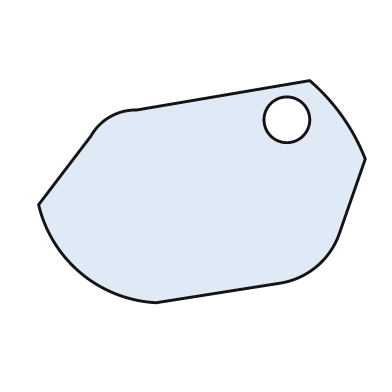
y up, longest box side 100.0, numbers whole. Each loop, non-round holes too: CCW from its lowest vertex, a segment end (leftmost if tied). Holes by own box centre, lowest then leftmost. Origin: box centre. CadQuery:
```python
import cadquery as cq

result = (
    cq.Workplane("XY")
    .moveTo(-14.0, -34.0)
    .lineTo(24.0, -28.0)
    .threePointArc((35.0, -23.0), (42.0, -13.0))
    .lineTo(50.0, 10.0)
    .threePointArc((43.0, 23.0), (33.0, 34.0))
    .lineTo(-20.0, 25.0)
    .threePointArc((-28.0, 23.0), (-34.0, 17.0))
    .lineTo(-50.0, -4.0)
    .threePointArc((-37.0, -25.0), (-14.0, -34.0))
    .close()
    .moveTo(26.0, 22.0)
    .circle(7.0)
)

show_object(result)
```